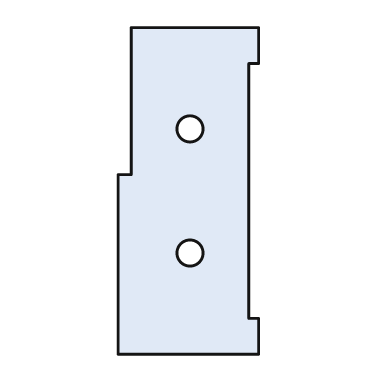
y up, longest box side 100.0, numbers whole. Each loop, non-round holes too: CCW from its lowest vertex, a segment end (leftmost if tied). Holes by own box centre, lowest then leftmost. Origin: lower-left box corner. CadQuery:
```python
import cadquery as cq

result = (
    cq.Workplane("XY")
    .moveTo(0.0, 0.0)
    .lineTo(43.0, 0.0)
    .lineTo(43.0, 11.0)
    .lineTo(40.0, 11.0)
    .lineTo(40.0, 89.0)
    .lineTo(43.0, 89.0)
    .lineTo(43.0, 100.0)
    .lineTo(4.0, 100.0)
    .lineTo(4.0, 55.0)
    .lineTo(0.0, 55.0)
    .close()
    .moveTo(22.0, 31.0)
    .circle(4.0)
    .moveTo(22.0, 69.0)
    .circle(4.0)
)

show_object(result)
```